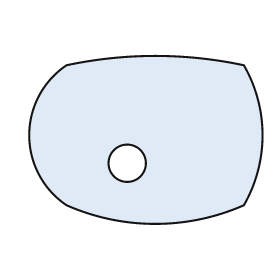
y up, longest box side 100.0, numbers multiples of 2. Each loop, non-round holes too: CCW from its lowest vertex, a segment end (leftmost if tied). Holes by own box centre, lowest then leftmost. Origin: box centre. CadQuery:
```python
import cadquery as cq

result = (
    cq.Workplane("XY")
    .moveTo(-34.0, -28.0)
    .threePointArc((4.0, -36.0), (42.0, -28.0))
    .threePointArc((50.0, 2.0), (42.0, 32.0))
    .threePointArc((4.0, 36.0), (-34.0, 32.0))
    .threePointArc((-50.0, 2.0), (-34.0, -28.0))
    .close()
    .moveTo(-8.0, -10.0)
    .circle(8.0)
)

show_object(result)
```